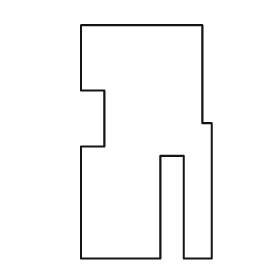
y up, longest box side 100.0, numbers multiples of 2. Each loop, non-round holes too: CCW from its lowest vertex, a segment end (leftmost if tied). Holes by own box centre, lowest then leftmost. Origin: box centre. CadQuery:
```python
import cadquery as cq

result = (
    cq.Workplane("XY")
    .moveTo(-28.0, -50.0)
    .lineTo(6.0, -50.0)
    .lineTo(6.0, -6.0)
    .lineTo(16.0, -6.0)
    .lineTo(16.0, -50.0)
    .lineTo(28.0, -50.0)
    .lineTo(28.0, 8.0)
    .lineTo(24.0, 8.0)
    .lineTo(24.0, 50.0)
    .lineTo(-28.0, 50.0)
    .lineTo(-28.0, 22.0)
    .lineTo(-18.0, 22.0)
    .lineTo(-18.0, -2.0)
    .lineTo(-28.0, -2.0)
    .close()
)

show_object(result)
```